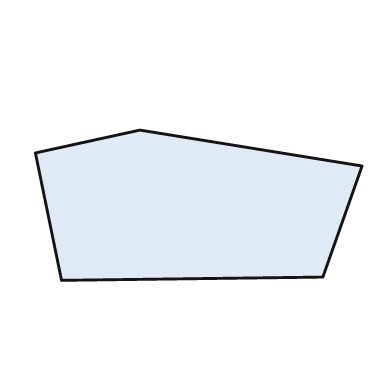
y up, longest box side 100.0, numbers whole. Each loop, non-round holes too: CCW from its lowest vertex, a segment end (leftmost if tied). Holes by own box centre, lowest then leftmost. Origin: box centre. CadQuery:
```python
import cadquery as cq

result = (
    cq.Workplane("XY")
    .moveTo(-42.0, -23.0)
    .lineTo(38.0, -22.0)
    .lineTo(50.0, 12.0)
    .lineTo(-18.0, 23.0)
    .lineTo(-50.0, 16.0)
    .close()
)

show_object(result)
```